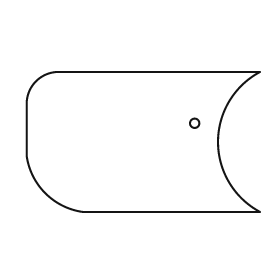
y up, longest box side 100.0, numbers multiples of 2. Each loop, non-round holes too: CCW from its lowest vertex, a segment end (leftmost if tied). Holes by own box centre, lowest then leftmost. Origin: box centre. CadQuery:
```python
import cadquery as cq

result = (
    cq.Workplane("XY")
    .moveTo(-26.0, -30.0)
    .lineTo(50.0, -30.0)
    .threePointArc((32.0, 0.0), (50.0, 30.0))
    .lineTo(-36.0, 30.0)
    .threePointArc((-46.0, 26.0), (-50.0, 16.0))
    .lineTo(-50.0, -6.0)
    .threePointArc((-42.0, -22.0), (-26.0, -30.0))
    .close()
    .moveTo(22.0, 8.0)
    .circle(2.0)
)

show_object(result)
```